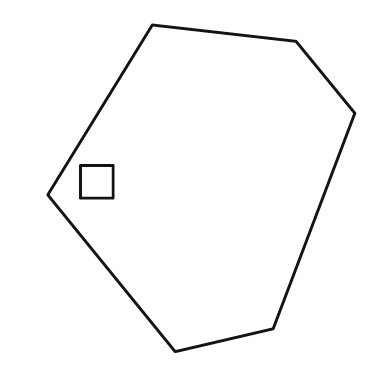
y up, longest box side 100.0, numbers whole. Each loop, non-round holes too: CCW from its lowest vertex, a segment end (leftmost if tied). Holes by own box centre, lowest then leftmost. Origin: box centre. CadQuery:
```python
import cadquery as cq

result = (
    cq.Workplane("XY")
    .moveTo(-8.0, -50.0)
    .lineTo(22.0, -43.0)
    .lineTo(47.0, 23.0)
    .lineTo(29.0, 45.0)
    .lineTo(-15.0, 50.0)
    .lineTo(-47.0, -2.0)
    .close()
    .moveTo(-37.0, -3.0)
    .lineTo(-27.0, -3.0)
    .lineTo(-27.0, 7.0)
    .lineTo(-37.0, 7.0)
    .close()
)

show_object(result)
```